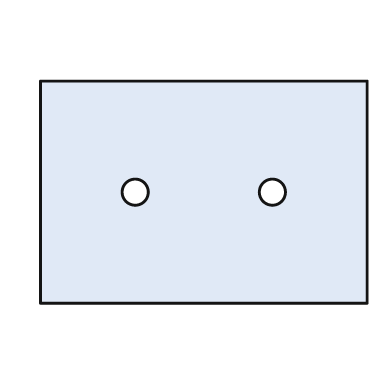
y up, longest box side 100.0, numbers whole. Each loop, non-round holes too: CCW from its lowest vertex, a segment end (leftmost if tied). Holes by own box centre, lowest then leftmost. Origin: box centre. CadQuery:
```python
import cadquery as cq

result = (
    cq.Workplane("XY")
    .moveTo(-50.0, -34.0)
    .lineTo(50.0, -34.0)
    .lineTo(50.0, 34.0)
    .lineTo(-50.0, 34.0)
    .close()
    .moveTo(-21.0, 0.0)
    .circle(4.0)
    .moveTo(21.0, 0.0)
    .circle(4.0)
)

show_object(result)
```